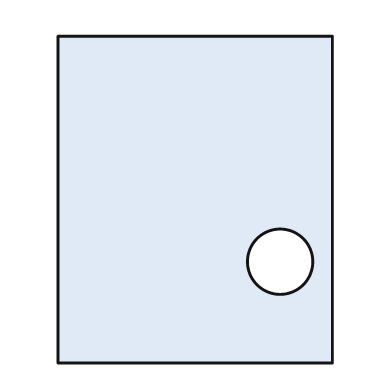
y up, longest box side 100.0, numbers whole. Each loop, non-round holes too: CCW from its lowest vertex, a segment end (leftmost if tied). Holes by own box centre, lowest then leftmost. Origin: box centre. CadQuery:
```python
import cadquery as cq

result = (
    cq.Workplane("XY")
    .moveTo(-42.0, -50.0)
    .lineTo(42.0, -50.0)
    .lineTo(42.0, 50.0)
    .lineTo(-42.0, 50.0)
    .close()
    .moveTo(26.0, -19.0)
    .circle(10.0)
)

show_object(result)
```